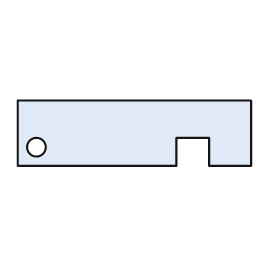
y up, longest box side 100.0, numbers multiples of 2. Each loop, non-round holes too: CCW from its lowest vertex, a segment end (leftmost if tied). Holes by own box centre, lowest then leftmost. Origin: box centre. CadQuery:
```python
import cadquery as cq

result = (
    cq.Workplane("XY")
    .moveTo(-50.0, -14.0)
    .lineTo(18.0, -14.0)
    .lineTo(18.0, -2.0)
    .lineTo(32.0, -2.0)
    .lineTo(32.0, -14.0)
    .lineTo(50.0, -14.0)
    .lineTo(50.0, 14.0)
    .lineTo(-50.0, 14.0)
    .close()
    .moveTo(-42.0, -6.0)
    .circle(4.0)
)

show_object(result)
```